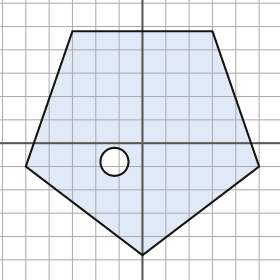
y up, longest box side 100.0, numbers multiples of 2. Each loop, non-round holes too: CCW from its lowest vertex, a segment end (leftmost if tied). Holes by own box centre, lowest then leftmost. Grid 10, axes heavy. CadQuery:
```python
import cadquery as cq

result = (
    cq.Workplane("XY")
    .moveTo(0.0, -48.0)
    .lineTo(50.0, -10.0)
    .lineTo(30.0, 48.0)
    .lineTo(-30.0, 48.0)
    .lineTo(-50.0, -10.0)
    .close()
    .moveTo(-12.0, -8.0)
    .circle(6.0)
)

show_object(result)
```